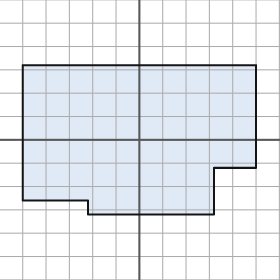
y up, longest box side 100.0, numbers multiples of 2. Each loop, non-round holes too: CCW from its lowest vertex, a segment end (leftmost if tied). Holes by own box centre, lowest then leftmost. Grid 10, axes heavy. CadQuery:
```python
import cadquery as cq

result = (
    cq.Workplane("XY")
    .moveTo(-22.0, -32.0)
    .lineTo(32.0, -32.0)
    .lineTo(32.0, -12.0)
    .lineTo(50.0, -12.0)
    .lineTo(50.0, 32.0)
    .lineTo(-50.0, 32.0)
    .lineTo(-50.0, -26.0)
    .lineTo(-22.0, -26.0)
    .close()
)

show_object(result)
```